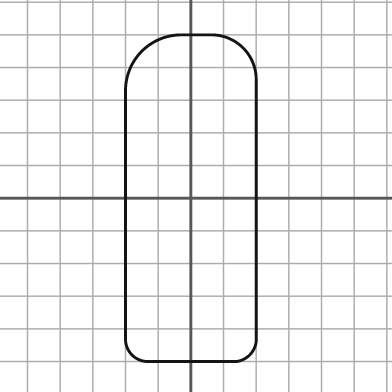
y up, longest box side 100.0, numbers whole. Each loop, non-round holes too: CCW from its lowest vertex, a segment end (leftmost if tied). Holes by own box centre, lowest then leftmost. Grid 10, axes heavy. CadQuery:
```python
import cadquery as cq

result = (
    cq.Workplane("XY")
    .moveTo(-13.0, -50.0)
    .lineTo(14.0, -50.0)
    .threePointArc((18.0, -48.0), (20.0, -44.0))
    .lineTo(20.0, 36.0)
    .threePointArc((16.0, 46.0), (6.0, 50.0))
    .lineTo(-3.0, 50.0)
    .threePointArc((-15.0, 45.0), (-20.0, 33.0))
    .lineTo(-20.0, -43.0)
    .threePointArc((-18.0, -48.0), (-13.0, -50.0))
    .close()
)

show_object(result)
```